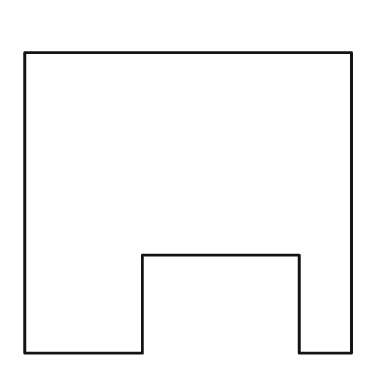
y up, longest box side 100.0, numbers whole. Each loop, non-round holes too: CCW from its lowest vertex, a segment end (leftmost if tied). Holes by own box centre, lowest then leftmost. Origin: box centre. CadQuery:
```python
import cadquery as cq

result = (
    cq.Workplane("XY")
    .moveTo(-50.0, -46.0)
    .lineTo(-14.0, -46.0)
    .lineTo(-14.0, -16.0)
    .lineTo(34.0, -16.0)
    .lineTo(34.0, -46.0)
    .lineTo(50.0, -46.0)
    .lineTo(50.0, 46.0)
    .lineTo(-50.0, 46.0)
    .close()
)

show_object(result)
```